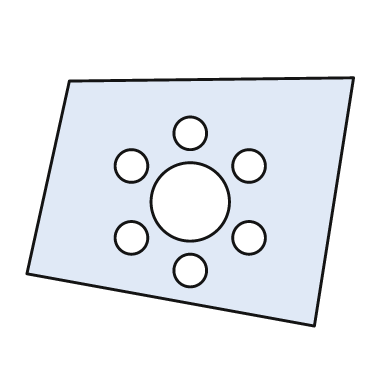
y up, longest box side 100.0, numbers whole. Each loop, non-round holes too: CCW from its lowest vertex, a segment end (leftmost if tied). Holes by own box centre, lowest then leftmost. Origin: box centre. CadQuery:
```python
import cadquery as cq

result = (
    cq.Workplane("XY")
    .moveTo(38.0, -38.0)
    .lineTo(50.0, 38.0)
    .lineTo(-37.0, 37.0)
    .lineTo(-50.0, -22.0)
    .close()
    .moveTo(0.0, -21.0)
    .circle(5.0)
    .moveTo(-18.0, -11.0)
    .circle(5.0)
    .moveTo(18.0, -11.0)
    .circle(5.0)
    .moveTo(0.0, 0.0)
    .circle(12.0)
    .moveTo(-18.0, 11.0)
    .circle(5.0)
    .moveTo(18.0, 11.0)
    .circle(5.0)
    .moveTo(0.0, 21.0)
    .circle(5.0)
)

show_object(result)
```